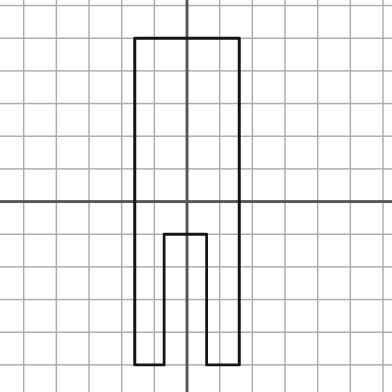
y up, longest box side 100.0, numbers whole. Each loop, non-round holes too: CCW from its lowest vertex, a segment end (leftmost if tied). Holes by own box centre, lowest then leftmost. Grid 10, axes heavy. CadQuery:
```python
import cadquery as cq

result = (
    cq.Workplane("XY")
    .moveTo(-16.0, -50.0)
    .lineTo(-7.0, -50.0)
    .lineTo(-7.0, -10.0)
    .lineTo(6.0, -10.0)
    .lineTo(6.0, -50.0)
    .lineTo(16.0, -50.0)
    .lineTo(16.0, 50.0)
    .lineTo(-16.0, 50.0)
    .close()
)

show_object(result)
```